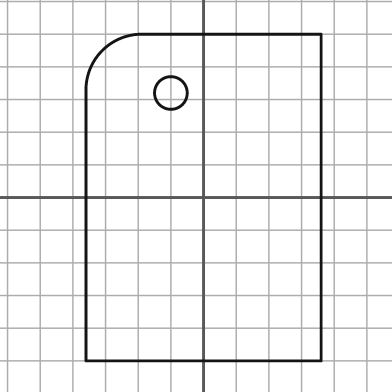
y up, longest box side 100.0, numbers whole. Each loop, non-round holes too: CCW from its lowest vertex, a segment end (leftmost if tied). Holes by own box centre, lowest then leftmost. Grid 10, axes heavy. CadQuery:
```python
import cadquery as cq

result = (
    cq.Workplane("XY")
    .moveTo(-36.0, -50.0)
    .lineTo(36.0, -50.0)
    .lineTo(36.0, 50.0)
    .lineTo(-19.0, 50.0)
    .threePointArc((-31.0, 45.0), (-36.0, 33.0))
    .close()
    .moveTo(-10.0, 32.0)
    .circle(5.0)
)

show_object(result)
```